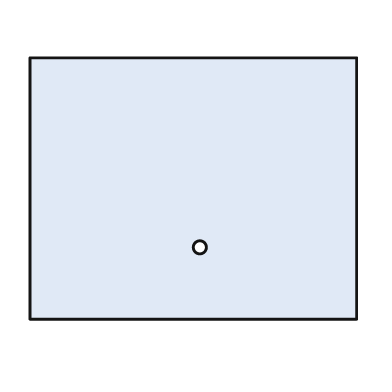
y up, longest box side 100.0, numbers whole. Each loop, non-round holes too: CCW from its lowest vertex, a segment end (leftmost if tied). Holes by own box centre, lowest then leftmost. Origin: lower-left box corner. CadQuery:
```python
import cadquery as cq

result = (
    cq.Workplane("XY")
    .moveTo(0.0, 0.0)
    .lineTo(100.0, 0.0)
    .lineTo(100.0, 80.0)
    .lineTo(0.0, 80.0)
    .close()
    .moveTo(52.0, 22.0)
    .circle(2.0)
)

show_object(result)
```